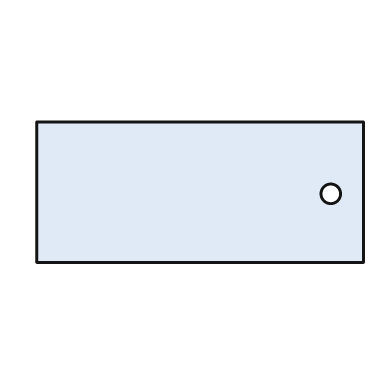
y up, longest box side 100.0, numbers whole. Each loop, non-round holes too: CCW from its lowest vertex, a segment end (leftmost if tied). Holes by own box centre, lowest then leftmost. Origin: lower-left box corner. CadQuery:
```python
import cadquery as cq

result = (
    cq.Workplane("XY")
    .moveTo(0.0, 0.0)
    .lineTo(100.0, 0.0)
    .lineTo(100.0, 43.0)
    .lineTo(0.0, 43.0)
    .close()
    .moveTo(90.0, 21.0)
    .circle(3.0)
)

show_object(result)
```